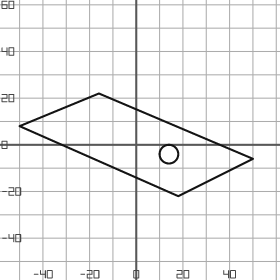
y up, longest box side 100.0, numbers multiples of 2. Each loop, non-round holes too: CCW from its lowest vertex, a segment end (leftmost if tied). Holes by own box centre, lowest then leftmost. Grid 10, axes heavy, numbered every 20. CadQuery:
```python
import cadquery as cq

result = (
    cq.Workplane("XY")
    .moveTo(18.0, -22.0)
    .lineTo(50.0, -6.0)
    .lineTo(-16.0, 22.0)
    .lineTo(-50.0, 8.0)
    .close()
    .moveTo(14.0, -4.0)
    .circle(4.0)
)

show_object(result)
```